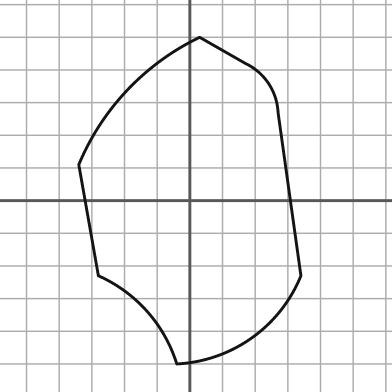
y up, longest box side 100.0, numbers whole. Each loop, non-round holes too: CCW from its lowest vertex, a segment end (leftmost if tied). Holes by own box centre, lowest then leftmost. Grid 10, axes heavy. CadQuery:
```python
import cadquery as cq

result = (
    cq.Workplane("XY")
    .moveTo(-4.0, -50.0)
    .threePointArc((19.0, -42.0), (34.0, -23.0))
    .lineTo(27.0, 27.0)
    .threePointArc((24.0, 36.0), (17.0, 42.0))
    .lineTo(3.0, 50.0)
    .threePointArc((-19.0, 34.0), (-34.0, 11.0))
    .lineTo(-28.0, -23.0)
    .threePointArc((-13.0, -34.0), (-4.0, -50.0))
    .close()
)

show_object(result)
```